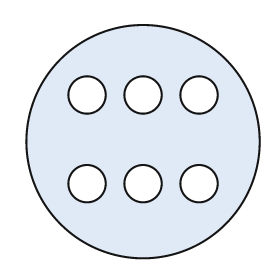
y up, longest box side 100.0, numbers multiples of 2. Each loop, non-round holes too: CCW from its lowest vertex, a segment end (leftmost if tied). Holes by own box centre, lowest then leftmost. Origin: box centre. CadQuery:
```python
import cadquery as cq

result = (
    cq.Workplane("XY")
    .moveTo(0.0, 0.0)
    .circle(50.0)
    .moveTo(-24.0, -18.0)
    .circle(8.0)
    .moveTo(0.0, -18.0)
    .circle(8.0)
    .moveTo(24.0, -18.0)
    .circle(8.0)
    .moveTo(-24.0, 20.0)
    .circle(8.0)
    .moveTo(0.0, 20.0)
    .circle(8.0)
    .moveTo(24.0, 20.0)
    .circle(8.0)
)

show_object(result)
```